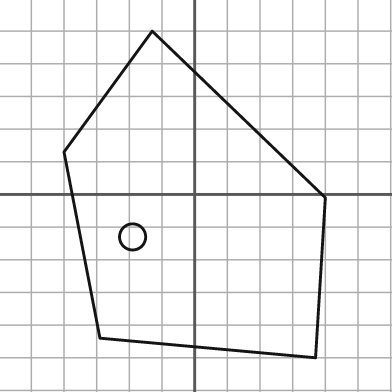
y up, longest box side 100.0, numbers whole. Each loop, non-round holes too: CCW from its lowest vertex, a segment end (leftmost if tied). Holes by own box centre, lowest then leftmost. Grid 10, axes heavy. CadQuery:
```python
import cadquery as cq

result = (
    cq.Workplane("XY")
    .moveTo(37.0, -50.0)
    .lineTo(40.0, -1.0)
    .lineTo(-13.0, 50.0)
    .lineTo(-40.0, 13.0)
    .lineTo(-29.0, -44.0)
    .close()
    .moveTo(-19.0, -13.0)
    .circle(4.0)
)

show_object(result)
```